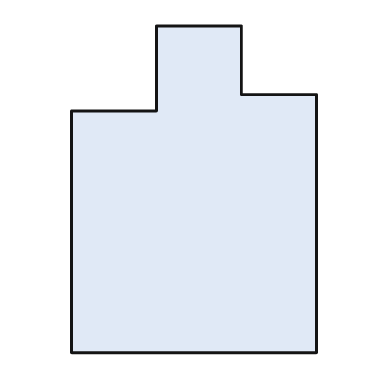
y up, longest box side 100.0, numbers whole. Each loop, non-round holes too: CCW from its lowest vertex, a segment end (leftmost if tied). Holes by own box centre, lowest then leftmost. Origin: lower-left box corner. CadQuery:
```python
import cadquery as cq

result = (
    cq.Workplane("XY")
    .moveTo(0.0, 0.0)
    .lineTo(75.0, 0.0)
    .lineTo(75.0, 79.0)
    .lineTo(52.0, 79.0)
    .lineTo(52.0, 100.0)
    .lineTo(26.0, 100.0)
    .lineTo(26.0, 74.0)
    .lineTo(0.0, 74.0)
    .close()
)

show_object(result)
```